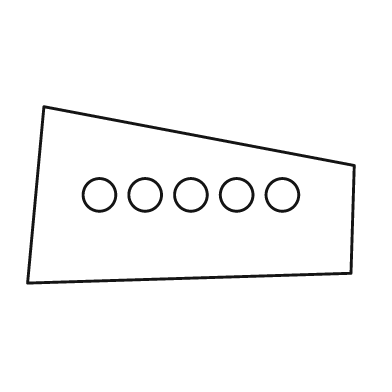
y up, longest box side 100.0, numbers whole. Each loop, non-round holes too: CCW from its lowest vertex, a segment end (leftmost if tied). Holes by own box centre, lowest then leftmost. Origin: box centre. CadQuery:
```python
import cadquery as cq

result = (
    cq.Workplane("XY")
    .moveTo(-50.0, -27.0)
    .lineTo(49.0, -24.0)
    .lineTo(50.0, 9.0)
    .lineTo(-45.0, 27.0)
    .close()
    .moveTo(-28.0, 0.0)
    .circle(5.0)
    .moveTo(-14.0, 0.0)
    .circle(5.0)
    .moveTo(0.0, 0.0)
    .circle(5.0)
    .moveTo(14.0, 0.0)
    .circle(5.0)
    .moveTo(28.0, 0.0)
    .circle(5.0)
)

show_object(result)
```